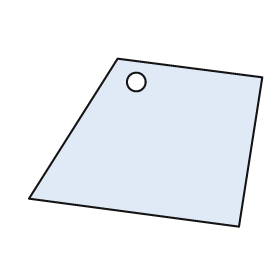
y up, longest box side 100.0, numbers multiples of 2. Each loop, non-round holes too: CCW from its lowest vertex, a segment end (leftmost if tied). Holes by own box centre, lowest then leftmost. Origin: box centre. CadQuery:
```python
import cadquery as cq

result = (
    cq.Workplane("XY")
    .moveTo(40.0, -36.0)
    .lineTo(50.0, 28.0)
    .lineTo(-12.0, 36.0)
    .lineTo(-50.0, -24.0)
    .close()
    .moveTo(-4.0, 26.0)
    .circle(4.0)
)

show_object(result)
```